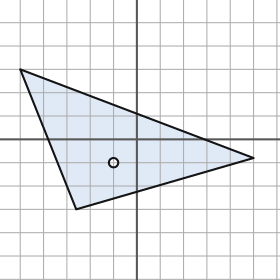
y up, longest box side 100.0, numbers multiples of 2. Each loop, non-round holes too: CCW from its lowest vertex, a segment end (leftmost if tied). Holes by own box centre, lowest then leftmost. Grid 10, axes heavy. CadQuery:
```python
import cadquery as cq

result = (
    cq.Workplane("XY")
    .moveTo(-26.0, -30.0)
    .lineTo(50.0, -8.0)
    .lineTo(-50.0, 30.0)
    .close()
    .moveTo(-10.0, -10.0)
    .circle(2.0)
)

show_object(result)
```